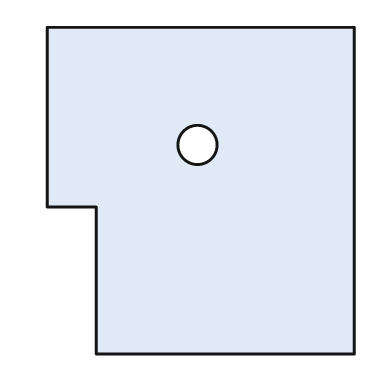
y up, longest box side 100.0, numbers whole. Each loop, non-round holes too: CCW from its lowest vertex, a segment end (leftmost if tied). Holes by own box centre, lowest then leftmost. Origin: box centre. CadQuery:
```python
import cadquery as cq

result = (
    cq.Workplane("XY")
    .moveTo(-32.0, -50.0)
    .lineTo(47.0, -50.0)
    .lineTo(47.0, 50.0)
    .lineTo(-47.0, 50.0)
    .lineTo(-47.0, -5.0)
    .lineTo(-32.0, -5.0)
    .close()
    .moveTo(-1.0, 14.0)
    .circle(6.0)
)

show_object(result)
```